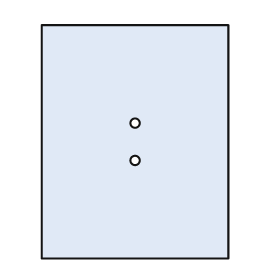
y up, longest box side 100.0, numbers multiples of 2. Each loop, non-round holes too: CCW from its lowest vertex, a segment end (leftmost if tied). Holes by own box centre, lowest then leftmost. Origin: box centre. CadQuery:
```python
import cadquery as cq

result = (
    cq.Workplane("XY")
    .moveTo(-40.0, -50.0)
    .lineTo(40.0, -50.0)
    .lineTo(40.0, 50.0)
    .lineTo(-40.0, 50.0)
    .close()
    .moveTo(0.0, -8.0)
    .circle(2.0)
    .moveTo(0.0, 8.0)
    .circle(2.0)
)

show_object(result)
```